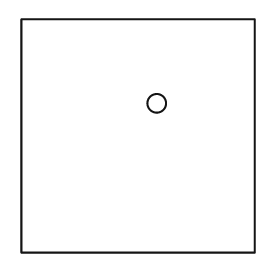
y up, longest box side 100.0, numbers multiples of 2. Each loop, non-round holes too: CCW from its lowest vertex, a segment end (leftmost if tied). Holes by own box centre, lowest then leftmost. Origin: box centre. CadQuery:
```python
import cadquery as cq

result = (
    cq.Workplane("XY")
    .moveTo(-50.0, -50.0)
    .lineTo(50.0, -50.0)
    .lineTo(50.0, 50.0)
    .lineTo(-50.0, 50.0)
    .close()
    .moveTo(8.0, 14.0)
    .circle(4.0)
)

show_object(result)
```